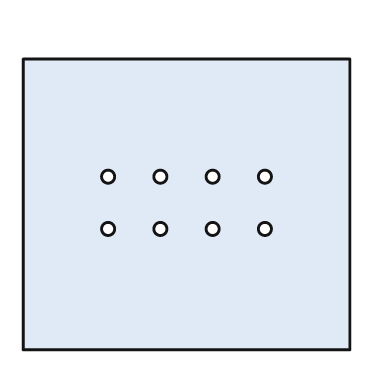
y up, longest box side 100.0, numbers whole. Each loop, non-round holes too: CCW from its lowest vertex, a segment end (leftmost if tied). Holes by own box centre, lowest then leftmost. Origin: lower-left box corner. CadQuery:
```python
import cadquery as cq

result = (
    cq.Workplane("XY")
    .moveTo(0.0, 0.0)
    .lineTo(100.0, 0.0)
    .lineTo(100.0, 89.0)
    .lineTo(0.0, 89.0)
    .close()
    .moveTo(26.0, 37.0)
    .circle(2.0)
    .moveTo(42.0, 37.0)
    .circle(2.0)
    .moveTo(58.0, 37.0)
    .circle(2.0)
    .moveTo(74.0, 37.0)
    .circle(2.0)
    .moveTo(26.0, 53.0)
    .circle(2.0)
    .moveTo(42.0, 53.0)
    .circle(2.0)
    .moveTo(58.0, 53.0)
    .circle(2.0)
    .moveTo(74.0, 53.0)
    .circle(2.0)
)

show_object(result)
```